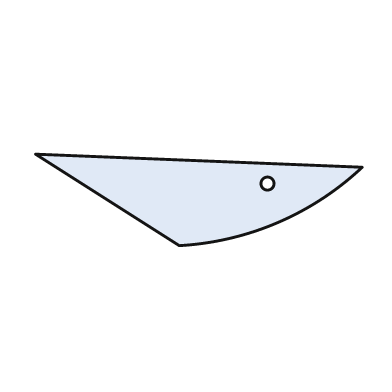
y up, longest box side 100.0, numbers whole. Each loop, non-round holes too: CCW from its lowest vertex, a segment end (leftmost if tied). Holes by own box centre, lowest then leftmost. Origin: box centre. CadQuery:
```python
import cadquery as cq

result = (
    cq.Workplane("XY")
    .moveTo(-6.0, -14.0)
    .threePointArc((24.0, -7.0), (50.0, 10.0))
    .lineTo(-50.0, 14.0)
    .close()
    .moveTo(21.0, 5.0)
    .circle(2.0)
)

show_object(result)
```